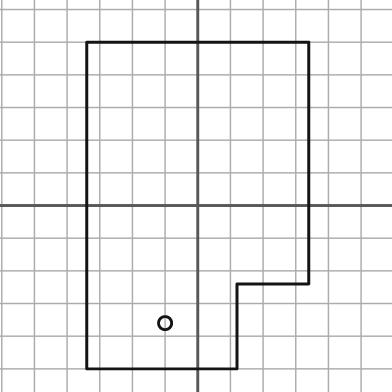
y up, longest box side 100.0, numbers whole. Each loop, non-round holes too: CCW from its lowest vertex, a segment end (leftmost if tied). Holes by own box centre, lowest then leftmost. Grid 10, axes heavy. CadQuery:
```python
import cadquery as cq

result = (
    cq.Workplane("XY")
    .moveTo(-34.0, -50.0)
    .lineTo(12.0, -50.0)
    .lineTo(12.0, -24.0)
    .lineTo(34.0, -24.0)
    .lineTo(34.0, 50.0)
    .lineTo(-34.0, 50.0)
    .close()
    .moveTo(-10.0, -36.0)
    .circle(2.0)
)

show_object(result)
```